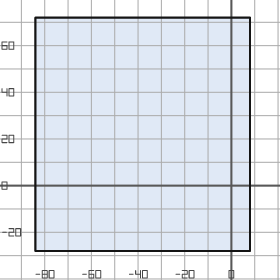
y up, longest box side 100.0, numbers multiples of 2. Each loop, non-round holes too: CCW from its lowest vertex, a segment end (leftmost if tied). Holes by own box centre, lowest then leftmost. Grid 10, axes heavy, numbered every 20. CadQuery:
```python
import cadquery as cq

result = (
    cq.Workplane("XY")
    .moveTo(-84.0, -28.0)
    .lineTo(8.0, -28.0)
    .lineTo(8.0, 72.0)
    .lineTo(-84.0, 72.0)
    .close()
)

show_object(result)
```